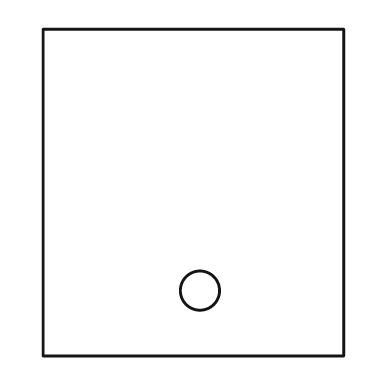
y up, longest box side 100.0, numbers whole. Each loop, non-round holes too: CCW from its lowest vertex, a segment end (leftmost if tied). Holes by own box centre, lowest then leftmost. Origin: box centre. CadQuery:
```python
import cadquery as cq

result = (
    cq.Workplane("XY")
    .moveTo(-46.0, -50.0)
    .lineTo(46.0, -50.0)
    .lineTo(46.0, 50.0)
    .lineTo(-46.0, 50.0)
    .close()
    .moveTo(2.0, -30.0)
    .circle(6.0)
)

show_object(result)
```